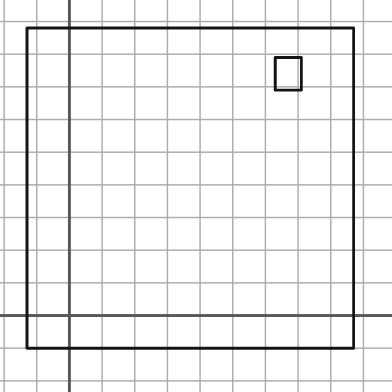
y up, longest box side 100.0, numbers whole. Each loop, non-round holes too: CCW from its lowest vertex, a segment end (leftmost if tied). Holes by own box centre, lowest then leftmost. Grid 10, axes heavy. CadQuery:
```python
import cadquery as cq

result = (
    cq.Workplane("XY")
    .moveTo(-13.0, -10.0)
    .lineTo(87.0, -10.0)
    .lineTo(87.0, 88.0)
    .lineTo(-13.0, 88.0)
    .close()
    .moveTo(63.0, 69.0)
    .lineTo(71.0, 69.0)
    .lineTo(71.0, 79.0)
    .lineTo(63.0, 79.0)
    .close()
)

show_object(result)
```